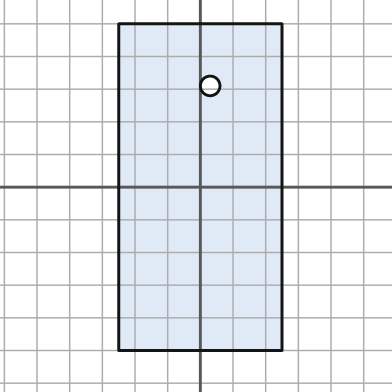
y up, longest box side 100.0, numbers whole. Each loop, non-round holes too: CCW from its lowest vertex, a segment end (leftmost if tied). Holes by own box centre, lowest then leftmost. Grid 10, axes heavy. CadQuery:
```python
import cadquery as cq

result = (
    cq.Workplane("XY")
    .moveTo(-25.0, -50.0)
    .lineTo(25.0, -50.0)
    .lineTo(25.0, 50.0)
    .lineTo(-25.0, 50.0)
    .close()
    .moveTo(3.0, 31.0)
    .circle(3.0)
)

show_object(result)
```